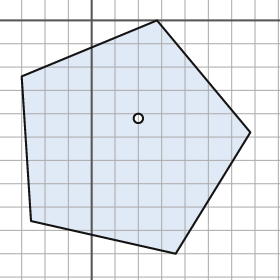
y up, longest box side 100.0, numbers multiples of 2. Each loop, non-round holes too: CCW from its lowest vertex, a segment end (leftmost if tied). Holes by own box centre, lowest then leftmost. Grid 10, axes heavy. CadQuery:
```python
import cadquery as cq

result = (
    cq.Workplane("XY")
    .moveTo(36.0, -100.0)
    .lineTo(68.0, -48.0)
    .lineTo(28.0, 0.0)
    .lineTo(-30.0, -24.0)
    .lineTo(-26.0, -86.0)
    .close()
    .moveTo(20.0, -42.0)
    .circle(2.0)
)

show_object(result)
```